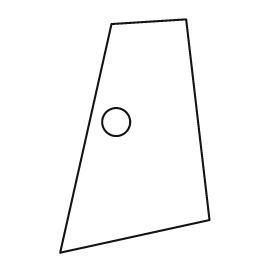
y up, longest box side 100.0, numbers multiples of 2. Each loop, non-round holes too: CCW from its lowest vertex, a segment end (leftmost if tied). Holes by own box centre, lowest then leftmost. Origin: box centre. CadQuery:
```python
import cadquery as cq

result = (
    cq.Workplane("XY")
    .moveTo(-32.0, -50.0)
    .lineTo(32.0, -36.0)
    .lineTo(22.0, 50.0)
    .lineTo(-10.0, 48.0)
    .close()
    .moveTo(-8.0, 6.0)
    .circle(6.0)
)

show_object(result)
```